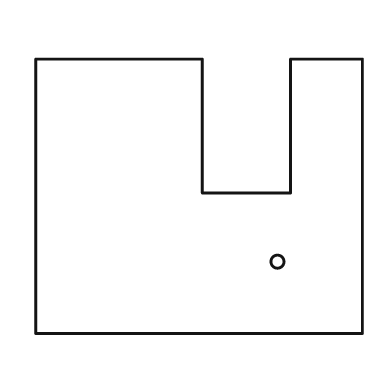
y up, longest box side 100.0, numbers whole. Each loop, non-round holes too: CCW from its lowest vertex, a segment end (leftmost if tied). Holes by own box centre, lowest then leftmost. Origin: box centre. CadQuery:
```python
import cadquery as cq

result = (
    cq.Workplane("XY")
    .moveTo(-50.0, -42.0)
    .lineTo(50.0, -42.0)
    .lineTo(50.0, 42.0)
    .lineTo(28.0, 42.0)
    .lineTo(28.0, 1.0)
    .lineTo(1.0, 1.0)
    .lineTo(1.0, 42.0)
    .lineTo(-50.0, 42.0)
    .close()
    .moveTo(24.0, -20.0)
    .circle(2.0)
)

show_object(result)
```